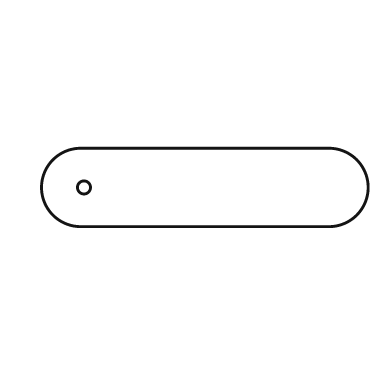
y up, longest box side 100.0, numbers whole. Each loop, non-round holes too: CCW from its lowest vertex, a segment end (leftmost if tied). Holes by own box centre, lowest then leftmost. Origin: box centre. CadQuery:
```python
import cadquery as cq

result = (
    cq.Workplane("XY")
    .moveTo(-38.0, -12.0)
    .lineTo(38.0, -12.0)
    .threePointArc((50.0, 0.0), (38.0, 12.0))
    .lineTo(-38.0, 12.0)
    .threePointArc((-50.0, 0.0), (-38.0, -12.0))
    .close()
    .moveTo(-37.0, 0.0)
    .circle(2.0)
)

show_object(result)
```